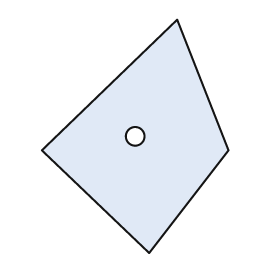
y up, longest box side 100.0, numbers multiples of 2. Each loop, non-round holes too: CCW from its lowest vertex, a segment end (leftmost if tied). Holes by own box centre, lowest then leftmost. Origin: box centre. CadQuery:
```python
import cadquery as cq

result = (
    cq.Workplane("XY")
    .moveTo(6.0, -50.0)
    .lineTo(40.0, -6.0)
    .lineTo(18.0, 50.0)
    .lineTo(-40.0, -6.0)
    .close()
    .moveTo(0.0, 0.0)
    .circle(4.0)
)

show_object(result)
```